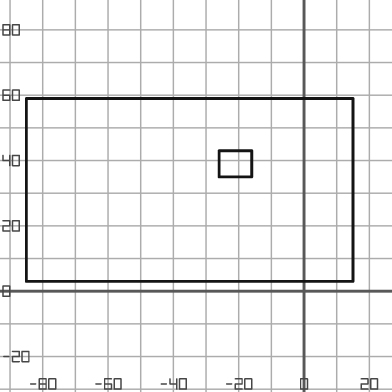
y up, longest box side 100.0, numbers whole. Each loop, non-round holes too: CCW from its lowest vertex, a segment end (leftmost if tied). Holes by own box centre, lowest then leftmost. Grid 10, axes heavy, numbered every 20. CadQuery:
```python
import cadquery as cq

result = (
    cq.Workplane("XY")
    .moveTo(-85.0, 3.0)
    .lineTo(15.0, 3.0)
    .lineTo(15.0, 59.0)
    .lineTo(-85.0, 59.0)
    .close()
    .moveTo(-26.0, 35.0)
    .lineTo(-16.0, 35.0)
    .lineTo(-16.0, 43.0)
    .lineTo(-26.0, 43.0)
    .close()
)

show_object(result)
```